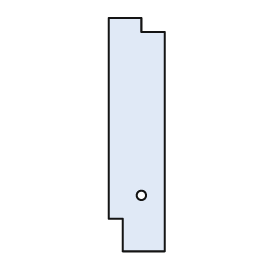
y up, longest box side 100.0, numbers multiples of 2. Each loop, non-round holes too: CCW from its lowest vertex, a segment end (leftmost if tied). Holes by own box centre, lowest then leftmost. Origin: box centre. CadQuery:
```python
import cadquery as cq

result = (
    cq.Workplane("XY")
    .moveTo(-6.0, -50.0)
    .lineTo(12.0, -50.0)
    .lineTo(12.0, 44.0)
    .lineTo(2.0, 44.0)
    .lineTo(2.0, 50.0)
    .lineTo(-12.0, 50.0)
    .lineTo(-12.0, -36.0)
    .lineTo(-6.0, -36.0)
    .close()
    .moveTo(2.0, -26.0)
    .circle(2.0)
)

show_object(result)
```